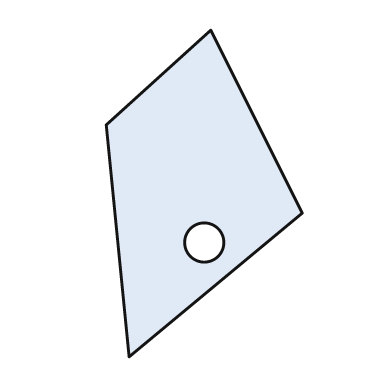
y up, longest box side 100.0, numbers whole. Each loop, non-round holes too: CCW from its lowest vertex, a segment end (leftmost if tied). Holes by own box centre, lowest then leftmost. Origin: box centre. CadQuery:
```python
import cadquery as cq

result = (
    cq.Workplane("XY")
    .moveTo(-23.0, -50.0)
    .lineTo(30.0, -6.0)
    .lineTo(2.0, 50.0)
    .lineTo(-30.0, 21.0)
    .close()
    .moveTo(0.0, -15.0)
    .circle(6.0)
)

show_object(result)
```